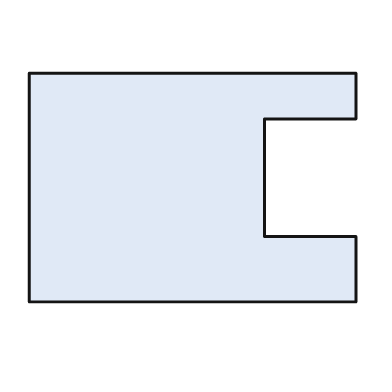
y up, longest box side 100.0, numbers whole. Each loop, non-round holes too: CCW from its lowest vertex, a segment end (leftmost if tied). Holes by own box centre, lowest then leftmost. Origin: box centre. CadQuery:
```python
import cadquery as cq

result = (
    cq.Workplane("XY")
    .moveTo(-50.0, -35.0)
    .lineTo(50.0, -35.0)
    .lineTo(50.0, -15.0)
    .lineTo(22.0, -15.0)
    .lineTo(22.0, 21.0)
    .lineTo(50.0, 21.0)
    .lineTo(50.0, 35.0)
    .lineTo(-50.0, 35.0)
    .close()
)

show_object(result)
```